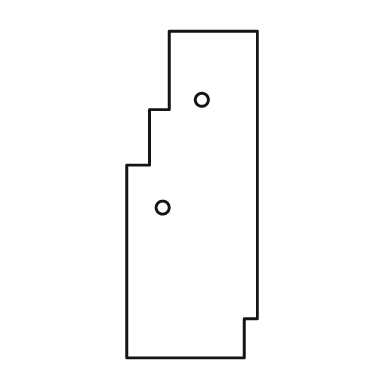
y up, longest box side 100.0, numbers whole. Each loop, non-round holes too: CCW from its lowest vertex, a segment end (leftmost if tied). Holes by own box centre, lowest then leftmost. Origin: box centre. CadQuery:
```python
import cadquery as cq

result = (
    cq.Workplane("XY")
    .moveTo(-20.0, -50.0)
    .lineTo(16.0, -50.0)
    .lineTo(16.0, -38.0)
    .lineTo(20.0, -38.0)
    .lineTo(20.0, 50.0)
    .lineTo(-7.0, 50.0)
    .lineTo(-7.0, 26.0)
    .lineTo(-13.0, 26.0)
    .lineTo(-13.0, 9.0)
    .lineTo(-20.0, 9.0)
    .close()
    .moveTo(-9.0, -4.0)
    .circle(2.0)
    .moveTo(3.0, 29.0)
    .circle(2.0)
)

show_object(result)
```